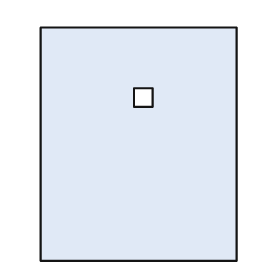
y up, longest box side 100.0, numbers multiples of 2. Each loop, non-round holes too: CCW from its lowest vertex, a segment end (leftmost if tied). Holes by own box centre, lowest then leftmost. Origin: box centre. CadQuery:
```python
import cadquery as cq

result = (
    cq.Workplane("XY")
    .moveTo(-42.0, -50.0)
    .lineTo(42.0, -50.0)
    .lineTo(42.0, 50.0)
    .lineTo(-42.0, 50.0)
    .close()
    .moveTo(-2.0, 16.0)
    .lineTo(6.0, 16.0)
    .lineTo(6.0, 24.0)
    .lineTo(-2.0, 24.0)
    .close()
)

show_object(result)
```